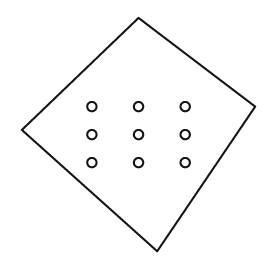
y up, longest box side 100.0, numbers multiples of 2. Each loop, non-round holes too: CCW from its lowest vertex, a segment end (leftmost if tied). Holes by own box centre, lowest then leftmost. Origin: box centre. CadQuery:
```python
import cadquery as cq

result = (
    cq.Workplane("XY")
    .moveTo(8.0, -50.0)
    .lineTo(50.0, 12.0)
    .lineTo(0.0, 50.0)
    .lineTo(-50.0, 2.0)
    .close()
    .moveTo(-20.0, -12.0)
    .circle(2.0)
    .moveTo(0.0, -12.0)
    .circle(2.0)
    .moveTo(20.0, -12.0)
    .circle(2.0)
    .moveTo(-20.0, 0.0)
    .circle(2.0)
    .moveTo(0.0, 0.0)
    .circle(2.0)
    .moveTo(20.0, 0.0)
    .circle(2.0)
    .moveTo(-20.0, 12.0)
    .circle(2.0)
    .moveTo(0.0, 12.0)
    .circle(2.0)
    .moveTo(20.0, 12.0)
    .circle(2.0)
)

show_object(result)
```